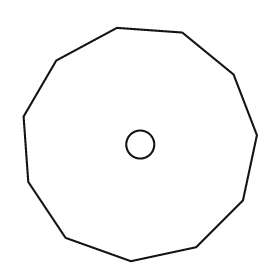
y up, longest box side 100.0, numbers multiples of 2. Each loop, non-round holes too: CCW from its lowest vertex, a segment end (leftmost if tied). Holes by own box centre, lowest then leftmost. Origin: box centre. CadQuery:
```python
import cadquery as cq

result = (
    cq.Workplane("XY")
    .moveTo(-4.0, -50.0)
    .lineTo(24.0, -44.0)
    .lineTo(44.0, -24.0)
    .lineTo(50.0, 4.0)
    .lineTo(40.0, 30.0)
    .lineTo(18.0, 48.0)
    .lineTo(-10.0, 50.0)
    .lineTo(-36.0, 36.0)
    .lineTo(-50.0, 12.0)
    .lineTo(-48.0, -16.0)
    .lineTo(-32.0, -40.0)
    .close()
    .moveTo(0.0, 0.0)
    .circle(6.0)
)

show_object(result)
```